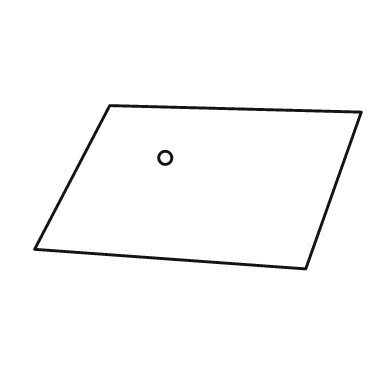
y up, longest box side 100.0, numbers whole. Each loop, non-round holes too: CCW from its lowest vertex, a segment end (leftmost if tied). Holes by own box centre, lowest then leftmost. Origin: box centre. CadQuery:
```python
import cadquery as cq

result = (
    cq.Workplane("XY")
    .moveTo(33.0, -25.0)
    .lineTo(50.0, 23.0)
    .lineTo(-27.0, 25.0)
    .lineTo(-50.0, -19.0)
    .close()
    .moveTo(-10.0, 9.0)
    .circle(2.0)
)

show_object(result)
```